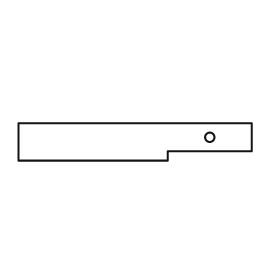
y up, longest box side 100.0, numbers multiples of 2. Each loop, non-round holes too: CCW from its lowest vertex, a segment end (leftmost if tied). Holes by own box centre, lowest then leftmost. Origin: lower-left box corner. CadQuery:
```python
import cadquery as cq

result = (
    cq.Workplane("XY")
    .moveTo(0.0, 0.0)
    .lineTo(64.0, 0.0)
    .lineTo(64.0, 4.0)
    .lineTo(100.0, 4.0)
    .lineTo(100.0, 16.0)
    .lineTo(0.0, 16.0)
    .close()
    .moveTo(82.0, 10.0)
    .circle(2.0)
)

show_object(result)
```